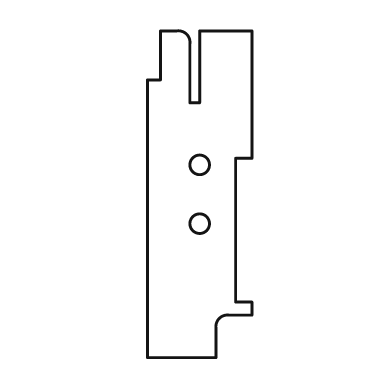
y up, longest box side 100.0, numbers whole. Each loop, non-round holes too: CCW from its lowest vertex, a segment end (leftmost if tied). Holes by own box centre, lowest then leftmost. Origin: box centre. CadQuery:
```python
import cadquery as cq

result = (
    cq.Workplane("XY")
    .moveTo(-16.0, -50.0)
    .lineTo(5.0, -50.0)
    .lineTo(5.0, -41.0)
    .threePointArc((6.0, -38.0), (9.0, -37.0))
    .lineTo(16.0, -37.0)
    .lineTo(16.0, -33.0)
    .lineTo(11.0, -33.0)
    .lineTo(11.0, 11.0)
    .lineTo(16.0, 11.0)
    .lineTo(16.0, 50.0)
    .lineTo(0.0, 50.0)
    .lineTo(0.0, 28.0)
    .lineTo(-3.0, 28.0)
    .lineTo(-3.0, 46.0)
    .threePointArc((-4.0, 49.0), (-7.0, 50.0))
    .lineTo(-12.0, 50.0)
    .lineTo(-12.0, 35.0)
    .lineTo(-16.0, 35.0)
    .close()
    .moveTo(0.0, -9.0)
    .circle(3.0)
    .moveTo(0.0, 9.0)
    .circle(3.0)
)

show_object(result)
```